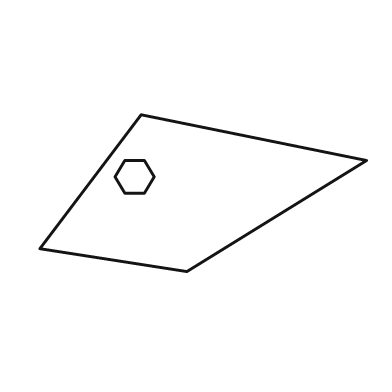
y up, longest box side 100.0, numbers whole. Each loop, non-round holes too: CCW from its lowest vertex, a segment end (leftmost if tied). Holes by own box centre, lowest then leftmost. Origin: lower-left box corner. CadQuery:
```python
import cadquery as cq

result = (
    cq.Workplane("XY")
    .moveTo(45.0, 0.0)
    .lineTo(100.0, 34.0)
    .lineTo(31.0, 48.0)
    .lineTo(0.0, 7.0)
    .close()
    .moveTo(26.0, 24.0)
    .lineTo(32.0, 24.0)
    .lineTo(35.0, 29.0)
    .lineTo(32.0, 34.0)
    .lineTo(26.0, 34.0)
    .lineTo(23.0, 29.0)
    .close()
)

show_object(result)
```